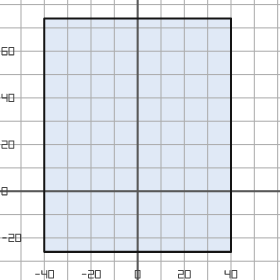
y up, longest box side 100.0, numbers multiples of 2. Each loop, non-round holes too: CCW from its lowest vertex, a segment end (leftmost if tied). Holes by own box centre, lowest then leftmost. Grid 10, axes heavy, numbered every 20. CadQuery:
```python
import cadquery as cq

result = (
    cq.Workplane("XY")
    .moveTo(-40.0, -26.0)
    .lineTo(40.0, -26.0)
    .lineTo(40.0, 74.0)
    .lineTo(-40.0, 74.0)
    .close()
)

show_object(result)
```